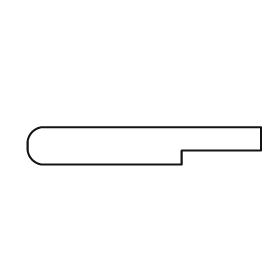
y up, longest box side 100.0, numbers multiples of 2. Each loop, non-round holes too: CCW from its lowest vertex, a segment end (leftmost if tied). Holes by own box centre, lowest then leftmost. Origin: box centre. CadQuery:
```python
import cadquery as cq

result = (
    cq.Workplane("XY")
    .moveTo(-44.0, -8.0)
    .lineTo(16.0, -8.0)
    .lineTo(16.0, -2.0)
    .lineTo(50.0, -2.0)
    .lineTo(50.0, 8.0)
    .lineTo(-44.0, 8.0)
    .threePointArc((-48.0, 6.0), (-50.0, 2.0))
    .lineTo(-50.0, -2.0)
    .threePointArc((-48.0, -6.0), (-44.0, -8.0))
    .close()
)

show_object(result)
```